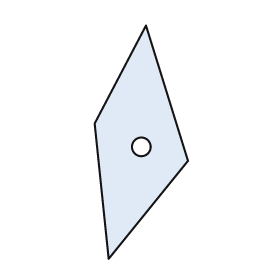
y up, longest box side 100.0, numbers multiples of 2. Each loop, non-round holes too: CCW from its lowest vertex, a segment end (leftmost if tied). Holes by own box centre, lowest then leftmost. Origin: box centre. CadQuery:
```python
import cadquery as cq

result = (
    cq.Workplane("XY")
    .moveTo(-14.0, -50.0)
    .lineTo(20.0, -8.0)
    .lineTo(2.0, 50.0)
    .lineTo(-20.0, 8.0)
    .close()
    .moveTo(0.0, -2.0)
    .circle(4.0)
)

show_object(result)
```